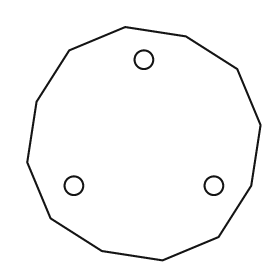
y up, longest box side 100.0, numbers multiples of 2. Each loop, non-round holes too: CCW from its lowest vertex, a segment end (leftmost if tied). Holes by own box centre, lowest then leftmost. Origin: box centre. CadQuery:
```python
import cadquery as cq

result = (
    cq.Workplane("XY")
    .moveTo(8.0, -50.0)
    .lineTo(32.0, -40.0)
    .lineTo(46.0, -18.0)
    .lineTo(50.0, 8.0)
    .lineTo(40.0, 32.0)
    .lineTo(18.0, 46.0)
    .lineTo(-8.0, 50.0)
    .lineTo(-32.0, 40.0)
    .lineTo(-46.0, 18.0)
    .lineTo(-50.0, -8.0)
    .lineTo(-40.0, -32.0)
    .lineTo(-18.0, -46.0)
    .close()
    .moveTo(-30.0, -18.0)
    .circle(4.0)
    .moveTo(30.0, -18.0)
    .circle(4.0)
    .moveTo(0.0, 36.0)
    .circle(4.0)
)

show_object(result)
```